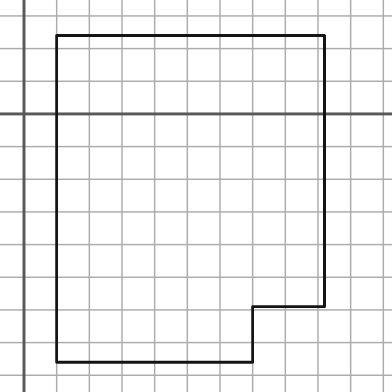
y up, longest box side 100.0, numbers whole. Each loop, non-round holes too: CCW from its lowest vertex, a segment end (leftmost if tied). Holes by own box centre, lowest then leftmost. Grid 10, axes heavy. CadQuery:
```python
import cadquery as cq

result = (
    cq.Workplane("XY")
    .moveTo(10.0, -76.0)
    .lineTo(70.0, -76.0)
    .lineTo(70.0, -59.0)
    .lineTo(92.0, -59.0)
    .lineTo(92.0, 24.0)
    .lineTo(10.0, 24.0)
    .close()
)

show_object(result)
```